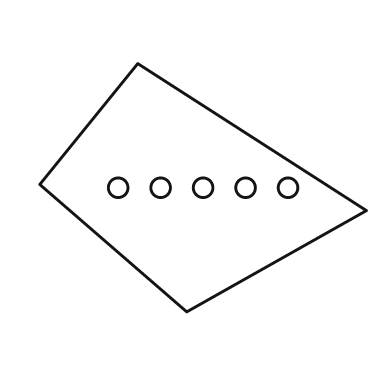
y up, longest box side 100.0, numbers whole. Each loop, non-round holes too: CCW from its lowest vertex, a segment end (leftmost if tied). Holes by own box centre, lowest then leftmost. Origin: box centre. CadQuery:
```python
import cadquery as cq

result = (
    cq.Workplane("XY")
    .moveTo(-5.0, -38.0)
    .lineTo(50.0, -7.0)
    .lineTo(-20.0, 38.0)
    .lineTo(-50.0, 1.0)
    .close()
    .moveTo(-26.0, 0.0)
    .circle(3.0)
    .moveTo(-13.0, 0.0)
    .circle(3.0)
    .moveTo(0.0, 0.0)
    .circle(3.0)
    .moveTo(13.0, 0.0)
    .circle(3.0)
    .moveTo(26.0, 0.0)
    .circle(3.0)
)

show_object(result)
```